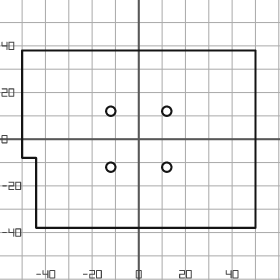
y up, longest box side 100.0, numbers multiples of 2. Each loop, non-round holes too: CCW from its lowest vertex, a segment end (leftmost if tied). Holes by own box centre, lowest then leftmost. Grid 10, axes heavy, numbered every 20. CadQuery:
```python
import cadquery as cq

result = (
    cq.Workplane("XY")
    .moveTo(-44.0, -38.0)
    .lineTo(50.0, -38.0)
    .lineTo(50.0, 38.0)
    .lineTo(-50.0, 38.0)
    .lineTo(-50.0, -8.0)
    .lineTo(-44.0, -8.0)
    .close()
    .moveTo(-12.0, -12.0)
    .circle(2.0)
    .moveTo(12.0, -12.0)
    .circle(2.0)
    .moveTo(-12.0, 12.0)
    .circle(2.0)
    .moveTo(12.0, 12.0)
    .circle(2.0)
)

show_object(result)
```